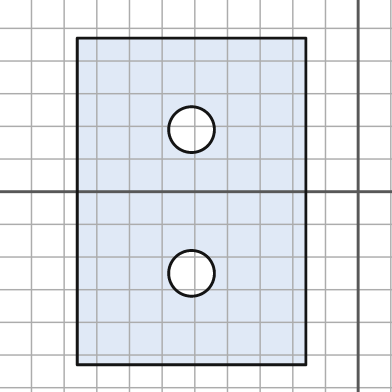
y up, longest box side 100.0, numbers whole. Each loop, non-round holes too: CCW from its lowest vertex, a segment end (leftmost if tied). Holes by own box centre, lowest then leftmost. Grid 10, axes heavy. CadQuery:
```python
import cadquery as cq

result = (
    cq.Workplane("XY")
    .moveTo(-86.0, -53.0)
    .lineTo(-16.0, -53.0)
    .lineTo(-16.0, 47.0)
    .lineTo(-86.0, 47.0)
    .close()
    .moveTo(-51.0, -25.0)
    .circle(7.0)
    .moveTo(-51.0, 19.0)
    .circle(7.0)
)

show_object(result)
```